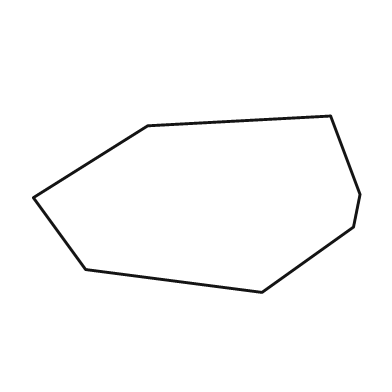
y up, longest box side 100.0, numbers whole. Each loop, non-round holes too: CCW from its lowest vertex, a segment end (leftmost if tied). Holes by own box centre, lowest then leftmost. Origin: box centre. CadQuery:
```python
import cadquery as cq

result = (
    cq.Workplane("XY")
    .moveTo(20.0, -27.0)
    .lineTo(48.0, -7.0)
    .lineTo(50.0, 3.0)
    .lineTo(41.0, 27.0)
    .lineTo(-15.0, 24.0)
    .lineTo(-50.0, 2.0)
    .lineTo(-34.0, -20.0)
    .close()
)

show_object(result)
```